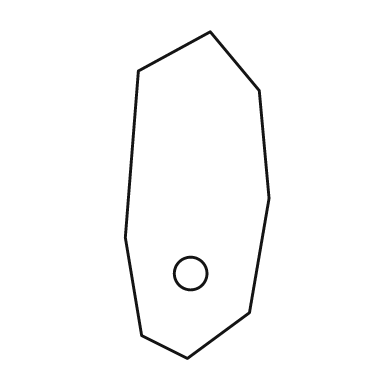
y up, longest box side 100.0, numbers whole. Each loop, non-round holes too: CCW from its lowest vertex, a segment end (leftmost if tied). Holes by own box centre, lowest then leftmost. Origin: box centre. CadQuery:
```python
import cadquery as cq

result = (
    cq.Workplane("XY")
    .moveTo(-3.0, -50.0)
    .lineTo(16.0, -36.0)
    .lineTo(22.0, -1.0)
    .lineTo(19.0, 32.0)
    .lineTo(4.0, 50.0)
    .lineTo(-18.0, 38.0)
    .lineTo(-22.0, -13.0)
    .lineTo(-17.0, -43.0)
    .close()
    .moveTo(-2.0, -24.0)
    .circle(5.0)
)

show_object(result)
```